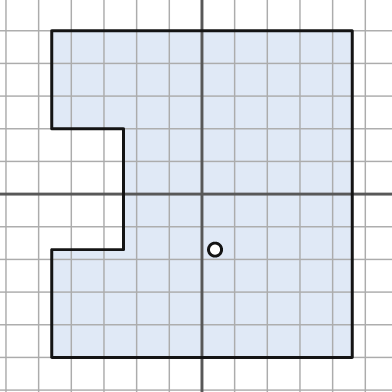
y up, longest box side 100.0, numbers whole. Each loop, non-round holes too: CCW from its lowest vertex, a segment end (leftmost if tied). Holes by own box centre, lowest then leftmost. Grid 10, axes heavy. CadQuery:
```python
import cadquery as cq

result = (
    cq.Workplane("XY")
    .moveTo(-46.0, -50.0)
    .lineTo(46.0, -50.0)
    .lineTo(46.0, 50.0)
    .lineTo(-46.0, 50.0)
    .lineTo(-46.0, 20.0)
    .lineTo(-24.0, 20.0)
    .lineTo(-24.0, -17.0)
    .lineTo(-46.0, -17.0)
    .close()
    .moveTo(4.0, -17.0)
    .circle(2.0)
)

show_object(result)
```